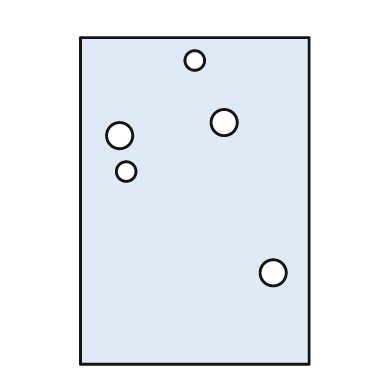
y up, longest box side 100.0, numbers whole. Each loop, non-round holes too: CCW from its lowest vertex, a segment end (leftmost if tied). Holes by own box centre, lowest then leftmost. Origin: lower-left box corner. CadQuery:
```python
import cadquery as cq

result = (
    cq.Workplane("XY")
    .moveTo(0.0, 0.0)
    .lineTo(70.0, 0.0)
    .lineTo(70.0, 100.0)
    .lineTo(0.0, 100.0)
    .close()
    .moveTo(59.0, 28.0)
    .circle(4.0)
    .moveTo(14.0, 59.0)
    .circle(3.0)
    .moveTo(12.0, 70.0)
    .circle(4.0)
    .moveTo(44.0, 74.0)
    .circle(4.0)
    .moveTo(35.0, 93.0)
    .circle(3.0)
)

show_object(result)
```